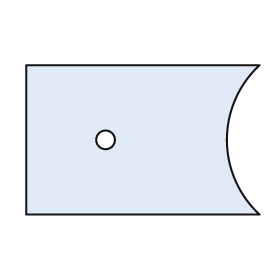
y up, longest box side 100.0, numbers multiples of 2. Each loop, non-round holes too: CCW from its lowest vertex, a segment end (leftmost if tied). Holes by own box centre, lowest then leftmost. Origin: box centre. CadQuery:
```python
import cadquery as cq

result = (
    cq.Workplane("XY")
    .moveTo(-50.0, -32.0)
    .lineTo(50.0, -32.0)
    .threePointArc((36.0, 0.0), (50.0, 32.0))
    .lineTo(-50.0, 32.0)
    .close()
    .moveTo(-16.0, 0.0)
    .circle(4.0)
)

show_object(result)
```